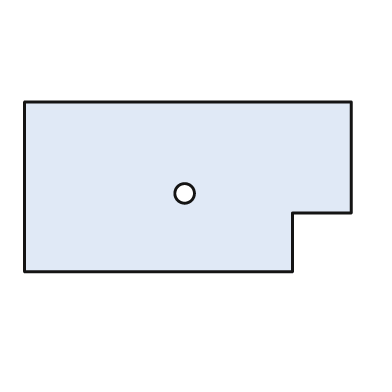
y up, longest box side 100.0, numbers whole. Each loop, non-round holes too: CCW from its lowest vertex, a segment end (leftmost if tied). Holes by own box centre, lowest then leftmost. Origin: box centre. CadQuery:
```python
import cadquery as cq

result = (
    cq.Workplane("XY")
    .moveTo(-50.0, -26.0)
    .lineTo(32.0, -26.0)
    .lineTo(32.0, -8.0)
    .lineTo(50.0, -8.0)
    .lineTo(50.0, 26.0)
    .lineTo(-50.0, 26.0)
    .close()
    .moveTo(-1.0, -2.0)
    .circle(3.0)
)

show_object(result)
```